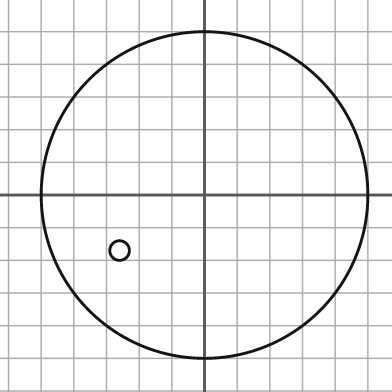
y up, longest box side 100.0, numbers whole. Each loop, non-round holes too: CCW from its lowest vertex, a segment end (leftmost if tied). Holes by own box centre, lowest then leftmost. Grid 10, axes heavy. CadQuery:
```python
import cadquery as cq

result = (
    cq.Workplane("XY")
    .moveTo(0.0, 0.0)
    .circle(50.0)
    .moveTo(-26.0, -17.0)
    .circle(3.0)
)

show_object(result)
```